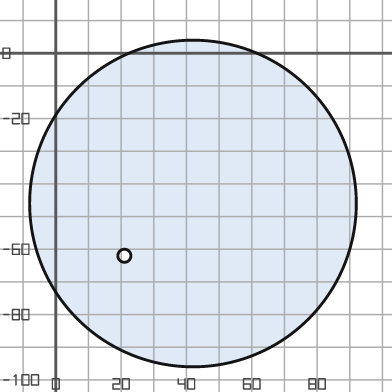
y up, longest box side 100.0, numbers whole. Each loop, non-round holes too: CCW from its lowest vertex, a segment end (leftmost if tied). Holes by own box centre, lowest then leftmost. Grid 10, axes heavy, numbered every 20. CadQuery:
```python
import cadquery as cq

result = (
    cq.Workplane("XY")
    .moveTo(42.0, -46.0)
    .circle(50.0)
    .moveTo(21.0, -62.0)
    .circle(2.0)
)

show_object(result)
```